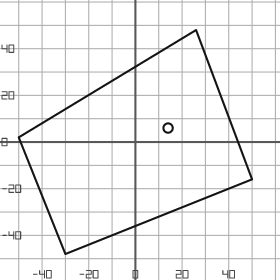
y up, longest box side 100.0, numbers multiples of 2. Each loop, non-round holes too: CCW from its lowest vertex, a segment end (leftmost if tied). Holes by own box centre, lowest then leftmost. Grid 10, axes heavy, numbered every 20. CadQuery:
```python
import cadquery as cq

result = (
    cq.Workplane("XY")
    .moveTo(-30.0, -48.0)
    .lineTo(50.0, -16.0)
    .lineTo(26.0, 48.0)
    .lineTo(-50.0, 2.0)
    .close()
    .moveTo(14.0, 6.0)
    .circle(2.0)
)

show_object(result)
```